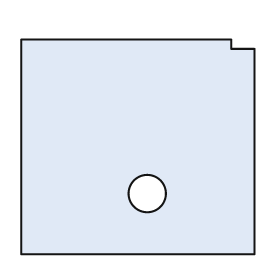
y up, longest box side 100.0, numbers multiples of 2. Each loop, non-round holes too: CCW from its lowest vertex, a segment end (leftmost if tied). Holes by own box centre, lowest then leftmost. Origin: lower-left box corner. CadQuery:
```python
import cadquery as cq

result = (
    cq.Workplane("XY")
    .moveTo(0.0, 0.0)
    .lineTo(100.0, 0.0)
    .lineTo(100.0, 88.0)
    .lineTo(90.0, 88.0)
    .lineTo(90.0, 92.0)
    .lineTo(0.0, 92.0)
    .close()
    .moveTo(54.0, 26.0)
    .circle(8.0)
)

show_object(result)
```